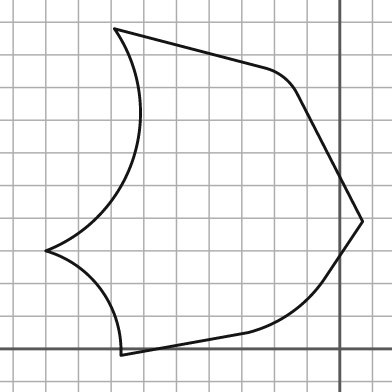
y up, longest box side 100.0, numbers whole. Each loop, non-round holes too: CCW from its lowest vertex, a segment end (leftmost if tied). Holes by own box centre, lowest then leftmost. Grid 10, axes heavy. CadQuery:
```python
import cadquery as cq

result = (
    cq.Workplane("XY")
    .moveTo(-67.0, -2.0)
    .lineTo(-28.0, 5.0)
    .threePointArc((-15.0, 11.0), (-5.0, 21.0))
    .lineTo(7.0, 39.0)
    .lineTo(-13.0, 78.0)
    .threePointArc((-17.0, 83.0), (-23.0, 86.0))
    .lineTo(-69.0, 98.0)
    .threePointArc((-63.0, 59.0), (-90.0, 30.0))
    .threePointArc((-73.0, 18.0), (-67.0, -2.0))
    .close()
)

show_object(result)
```